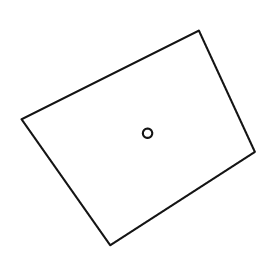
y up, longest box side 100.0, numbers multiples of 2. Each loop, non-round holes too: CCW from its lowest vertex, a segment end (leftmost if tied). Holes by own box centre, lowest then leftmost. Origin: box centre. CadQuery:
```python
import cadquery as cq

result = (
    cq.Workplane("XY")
    .moveTo(-12.0, -46.0)
    .lineTo(50.0, -6.0)
    .lineTo(26.0, 46.0)
    .lineTo(-50.0, 8.0)
    .close()
    .moveTo(4.0, 2.0)
    .circle(2.0)
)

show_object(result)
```